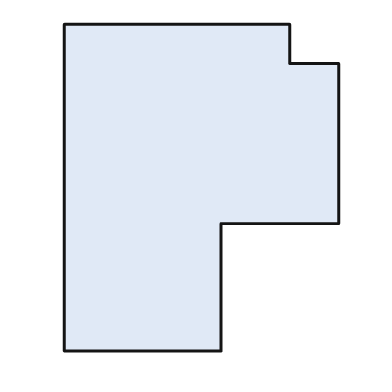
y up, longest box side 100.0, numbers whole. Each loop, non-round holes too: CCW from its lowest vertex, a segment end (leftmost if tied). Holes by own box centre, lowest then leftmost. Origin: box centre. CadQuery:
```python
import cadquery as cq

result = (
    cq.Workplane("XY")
    .moveTo(-42.0, -50.0)
    .lineTo(6.0, -50.0)
    .lineTo(6.0, -11.0)
    .lineTo(42.0, -11.0)
    .lineTo(42.0, 38.0)
    .lineTo(27.0, 38.0)
    .lineTo(27.0, 50.0)
    .lineTo(-42.0, 50.0)
    .close()
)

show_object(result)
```